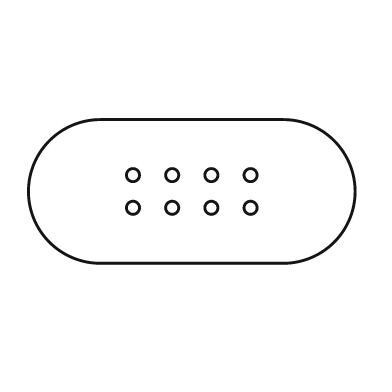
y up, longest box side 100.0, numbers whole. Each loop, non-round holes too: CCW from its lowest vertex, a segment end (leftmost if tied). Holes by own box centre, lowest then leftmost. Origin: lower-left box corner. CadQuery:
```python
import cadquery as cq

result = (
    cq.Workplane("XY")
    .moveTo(22.0, 0.0)
    .lineTo(78.0, 0.0)
    .threePointArc((100.0, 22.0), (78.0, 44.0))
    .lineTo(22.0, 44.0)
    .threePointArc((0.0, 22.0), (22.0, 0.0))
    .close()
    .moveTo(32.0, 17.0)
    .circle(2.0)
    .moveTo(44.0, 17.0)
    .circle(2.0)
    .moveTo(56.0, 17.0)
    .circle(2.0)
    .moveTo(68.0, 17.0)
    .circle(2.0)
    .moveTo(32.0, 27.0)
    .circle(2.0)
    .moveTo(44.0, 27.0)
    .circle(2.0)
    .moveTo(56.0, 27.0)
    .circle(2.0)
    .moveTo(68.0, 27.0)
    .circle(2.0)
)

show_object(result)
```